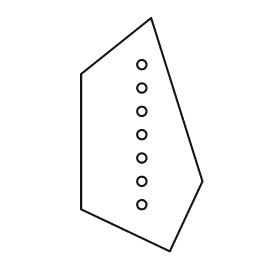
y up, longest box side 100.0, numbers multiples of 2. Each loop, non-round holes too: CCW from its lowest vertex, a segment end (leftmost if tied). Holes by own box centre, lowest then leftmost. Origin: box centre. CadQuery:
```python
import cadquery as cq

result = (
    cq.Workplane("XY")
    .moveTo(12.0, -50.0)
    .lineTo(26.0, -20.0)
    .lineTo(4.0, 50.0)
    .lineTo(-26.0, 26.0)
    .lineTo(-26.0, -32.0)
    .close()
    .moveTo(0.0, -30.0)
    .circle(2.0)
    .moveTo(0.0, -20.0)
    .circle(2.0)
    .moveTo(0.0, -10.0)
    .circle(2.0)
    .moveTo(0.0, 0.0)
    .circle(2.0)
    .moveTo(0.0, 10.0)
    .circle(2.0)
    .moveTo(0.0, 20.0)
    .circle(2.0)
    .moveTo(0.0, 30.0)
    .circle(2.0)
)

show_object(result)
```